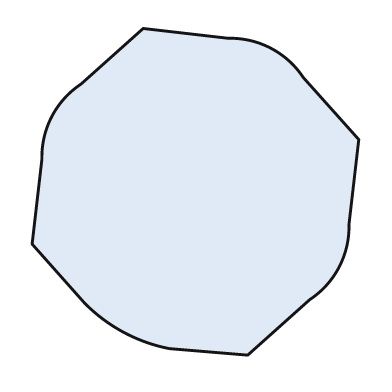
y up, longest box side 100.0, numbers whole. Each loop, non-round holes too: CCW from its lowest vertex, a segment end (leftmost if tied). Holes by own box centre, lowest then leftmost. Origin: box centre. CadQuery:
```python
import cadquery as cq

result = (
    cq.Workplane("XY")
    .moveTo(16.0, -50.0)
    .lineTo(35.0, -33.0)
    .threePointArc((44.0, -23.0), (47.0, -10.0))
    .lineTo(50.0, 16.0)
    .lineTo(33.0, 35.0)
    .threePointArc((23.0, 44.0), (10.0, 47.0))
    .lineTo(-16.0, 50.0)
    .lineTo(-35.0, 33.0)
    .threePointArc((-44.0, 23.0), (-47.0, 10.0))
    .lineTo(-50.0, -16.0)
    .lineTo(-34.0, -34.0)
    .threePointArc((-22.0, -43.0), (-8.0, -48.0))
    .close()
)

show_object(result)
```